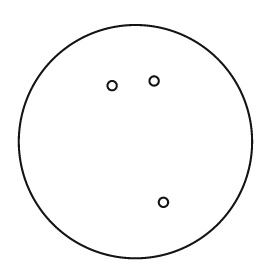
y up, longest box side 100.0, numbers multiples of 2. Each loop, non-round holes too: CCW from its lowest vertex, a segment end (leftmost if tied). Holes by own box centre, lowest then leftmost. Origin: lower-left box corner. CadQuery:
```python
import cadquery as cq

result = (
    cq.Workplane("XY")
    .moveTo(50.0, 50.0)
    .circle(50.0)
    .moveTo(62.0, 24.0)
    .circle(2.0)
    .moveTo(40.0, 74.0)
    .circle(2.0)
    .moveTo(58.0, 76.0)
    .circle(2.0)
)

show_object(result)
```